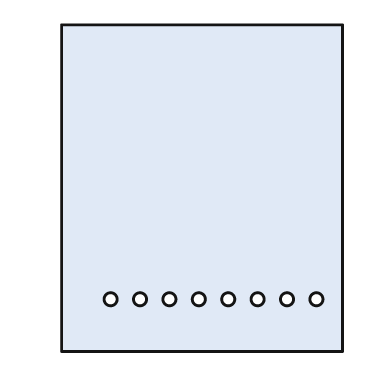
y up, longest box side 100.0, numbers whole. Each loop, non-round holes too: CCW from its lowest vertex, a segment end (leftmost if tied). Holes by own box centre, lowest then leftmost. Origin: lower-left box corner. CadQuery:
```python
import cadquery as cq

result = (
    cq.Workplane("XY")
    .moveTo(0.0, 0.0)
    .lineTo(86.0, 0.0)
    .lineTo(86.0, 100.0)
    .lineTo(0.0, 100.0)
    .close()
    .moveTo(15.0, 16.0)
    .circle(2.0)
    .moveTo(24.0, 16.0)
    .circle(2.0)
    .moveTo(33.0, 16.0)
    .circle(2.0)
    .moveTo(42.0, 16.0)
    .circle(2.0)
    .moveTo(51.0, 16.0)
    .circle(2.0)
    .moveTo(60.0, 16.0)
    .circle(2.0)
    .moveTo(69.0, 16.0)
    .circle(2.0)
    .moveTo(78.0, 16.0)
    .circle(2.0)
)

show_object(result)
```